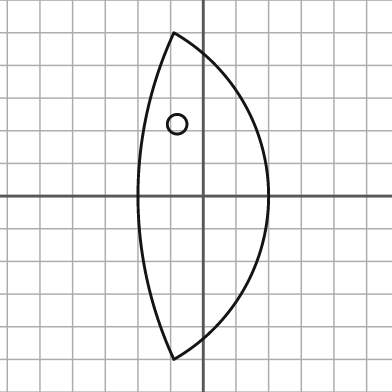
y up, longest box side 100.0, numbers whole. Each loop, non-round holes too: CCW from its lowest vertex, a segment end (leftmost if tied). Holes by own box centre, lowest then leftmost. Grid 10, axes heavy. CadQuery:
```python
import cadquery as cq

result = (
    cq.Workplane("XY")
    .moveTo(-9.0, -50.0)
    .threePointArc((20.0, 0.0), (-9.0, 50.0))
    .threePointArc((-20.0, 0.0), (-9.0, -50.0))
    .close()
    .moveTo(-8.0, 22.0)
    .circle(3.0)
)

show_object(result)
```